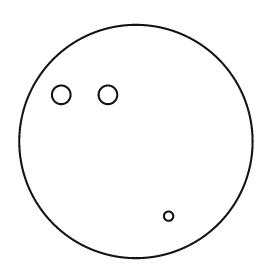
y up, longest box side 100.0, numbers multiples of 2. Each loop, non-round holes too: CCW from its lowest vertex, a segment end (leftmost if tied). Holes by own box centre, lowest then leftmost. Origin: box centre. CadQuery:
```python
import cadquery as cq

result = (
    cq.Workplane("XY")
    .moveTo(0.0, 0.0)
    .circle(50.0)
    .moveTo(14.0, -32.0)
    .circle(2.0)
    .moveTo(-32.0, 20.0)
    .circle(4.0)
    .moveTo(-12.0, 20.0)
    .circle(4.0)
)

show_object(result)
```